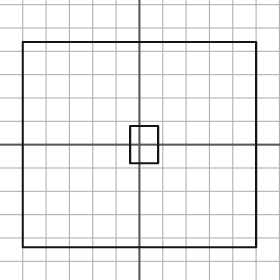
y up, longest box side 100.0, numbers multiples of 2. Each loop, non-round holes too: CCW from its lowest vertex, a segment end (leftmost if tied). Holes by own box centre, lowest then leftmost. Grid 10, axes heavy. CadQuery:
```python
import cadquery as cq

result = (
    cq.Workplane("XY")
    .moveTo(-50.0, -44.0)
    .lineTo(50.0, -44.0)
    .lineTo(50.0, 44.0)
    .lineTo(-50.0, 44.0)
    .close()
    .moveTo(-4.0, -8.0)
    .lineTo(8.0, -8.0)
    .lineTo(8.0, 8.0)
    .lineTo(-4.0, 8.0)
    .close()
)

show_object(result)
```